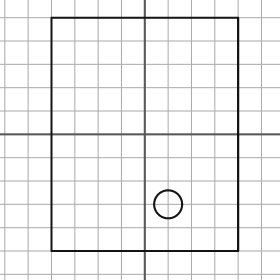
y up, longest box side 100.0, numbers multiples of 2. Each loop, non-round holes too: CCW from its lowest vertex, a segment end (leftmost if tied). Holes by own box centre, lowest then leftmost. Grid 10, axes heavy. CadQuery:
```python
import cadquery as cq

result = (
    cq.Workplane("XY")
    .moveTo(-40.0, -50.0)
    .lineTo(40.0, -50.0)
    .lineTo(40.0, 50.0)
    .lineTo(-40.0, 50.0)
    .close()
    .moveTo(10.0, -30.0)
    .circle(6.0)
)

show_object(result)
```